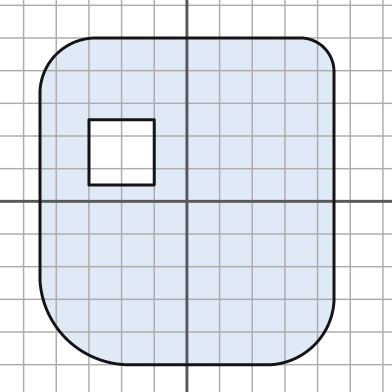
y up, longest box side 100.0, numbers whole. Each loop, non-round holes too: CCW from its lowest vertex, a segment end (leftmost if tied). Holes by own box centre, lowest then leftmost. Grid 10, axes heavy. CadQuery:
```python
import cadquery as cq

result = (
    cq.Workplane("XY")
    .moveTo(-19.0, -50.0)
    .lineTo(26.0, -50.0)
    .threePointArc((39.0, -44.0), (45.0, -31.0))
    .lineTo(45.0, 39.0)
    .threePointArc((42.0, 47.0), (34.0, 50.0))
    .lineTo(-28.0, 50.0)
    .threePointArc((-40.0, 45.0), (-45.0, 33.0))
    .lineTo(-45.0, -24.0)
    .threePointArc((-37.0, -42.0), (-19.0, -50.0))
    .close()
    .moveTo(-30.0, 5.0)
    .lineTo(-10.0, 5.0)
    .lineTo(-10.0, 25.0)
    .lineTo(-30.0, 25.0)
    .close()
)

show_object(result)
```